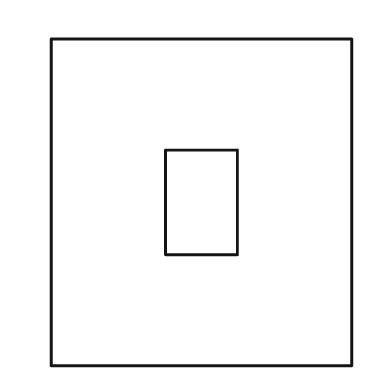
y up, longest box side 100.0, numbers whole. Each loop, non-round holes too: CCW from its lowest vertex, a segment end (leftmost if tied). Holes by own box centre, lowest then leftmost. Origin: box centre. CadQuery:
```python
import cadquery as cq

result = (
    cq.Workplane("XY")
    .moveTo(-46.0, -50.0)
    .lineTo(46.0, -50.0)
    .lineTo(46.0, 50.0)
    .lineTo(-46.0, 50.0)
    .close()
    .moveTo(-11.0, -16.0)
    .lineTo(11.0, -16.0)
    .lineTo(11.0, 16.0)
    .lineTo(-11.0, 16.0)
    .close()
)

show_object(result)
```